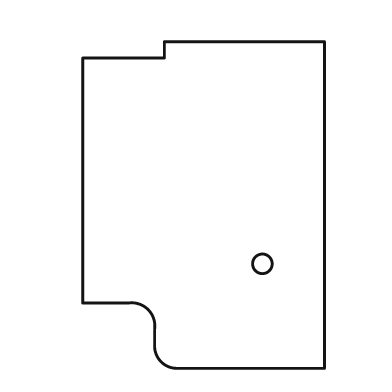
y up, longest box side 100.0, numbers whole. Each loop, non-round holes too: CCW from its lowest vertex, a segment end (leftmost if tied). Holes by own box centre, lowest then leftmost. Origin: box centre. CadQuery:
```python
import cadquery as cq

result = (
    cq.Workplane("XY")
    .moveTo(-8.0, -50.0)
    .lineTo(37.0, -50.0)
    .lineTo(37.0, 50.0)
    .lineTo(-12.0, 50.0)
    .lineTo(-12.0, 45.0)
    .lineTo(-37.0, 45.0)
    .lineTo(-37.0, -30.0)
    .lineTo(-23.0, -30.0)
    .threePointArc((-17.0, -32.0), (-15.0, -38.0))
    .lineTo(-15.0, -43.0)
    .threePointArc((-13.0, -48.0), (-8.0, -50.0))
    .close()
    .moveTo(18.0, -18.0)
    .circle(3.0)
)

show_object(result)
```